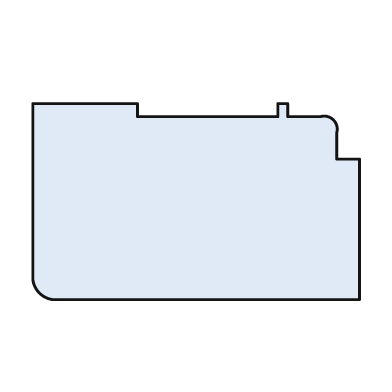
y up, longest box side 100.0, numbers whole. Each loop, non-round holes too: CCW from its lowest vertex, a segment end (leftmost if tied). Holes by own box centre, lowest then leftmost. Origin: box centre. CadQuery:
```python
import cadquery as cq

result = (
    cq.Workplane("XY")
    .moveTo(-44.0, -30.0)
    .lineTo(50.0, -30.0)
    .lineTo(50.0, 13.0)
    .lineTo(43.0, 13.0)
    .lineTo(43.0, 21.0)
    .threePointArc((42.0, 25.0), (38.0, 26.0))
    .lineTo(28.0, 26.0)
    .lineTo(28.0, 30.0)
    .lineTo(25.0, 30.0)
    .lineTo(25.0, 26.0)
    .lineTo(-18.0, 26.0)
    .lineTo(-18.0, 30.0)
    .lineTo(-50.0, 30.0)
    .lineTo(-50.0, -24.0)
    .threePointArc((-48.0, -28.0), (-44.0, -30.0))
    .close()
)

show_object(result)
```